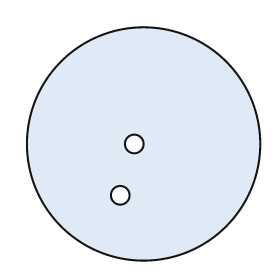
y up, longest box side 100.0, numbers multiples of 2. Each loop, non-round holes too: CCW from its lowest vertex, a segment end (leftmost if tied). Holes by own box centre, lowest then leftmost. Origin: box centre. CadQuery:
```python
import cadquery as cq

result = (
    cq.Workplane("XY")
    .moveTo(0.0, 0.0)
    .circle(50.0)
    .moveTo(-10.0, -22.0)
    .circle(4.0)
    .moveTo(-4.0, 0.0)
    .circle(4.0)
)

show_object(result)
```